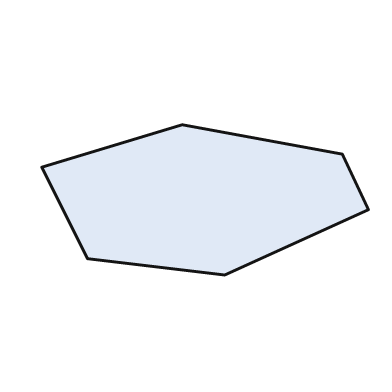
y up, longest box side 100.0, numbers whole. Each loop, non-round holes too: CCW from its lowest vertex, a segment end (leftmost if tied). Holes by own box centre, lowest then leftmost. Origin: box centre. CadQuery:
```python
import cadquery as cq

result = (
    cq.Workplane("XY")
    .moveTo(6.0, -23.0)
    .lineTo(50.0, -3.0)
    .lineTo(42.0, 14.0)
    .lineTo(-7.0, 23.0)
    .lineTo(-50.0, 10.0)
    .lineTo(-36.0, -18.0)
    .close()
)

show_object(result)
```